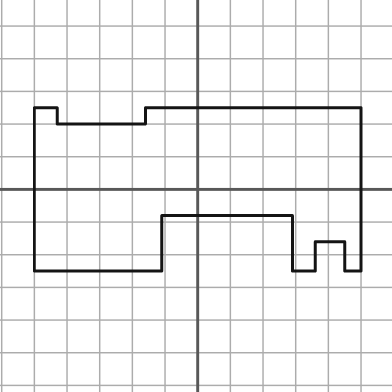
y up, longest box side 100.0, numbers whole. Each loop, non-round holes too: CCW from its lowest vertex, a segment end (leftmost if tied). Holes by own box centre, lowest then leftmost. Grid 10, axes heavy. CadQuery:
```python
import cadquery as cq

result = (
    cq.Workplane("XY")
    .moveTo(-50.0, -25.0)
    .lineTo(-11.0, -25.0)
    .lineTo(-11.0, -8.0)
    .lineTo(29.0, -8.0)
    .lineTo(29.0, -25.0)
    .lineTo(36.0, -25.0)
    .lineTo(36.0, -16.0)
    .lineTo(45.0, -16.0)
    .lineTo(45.0, -25.0)
    .lineTo(50.0, -25.0)
    .lineTo(50.0, 25.0)
    .lineTo(-16.0, 25.0)
    .lineTo(-16.0, 20.0)
    .lineTo(-43.0, 20.0)
    .lineTo(-43.0, 25.0)
    .lineTo(-50.0, 25.0)
    .close()
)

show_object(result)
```